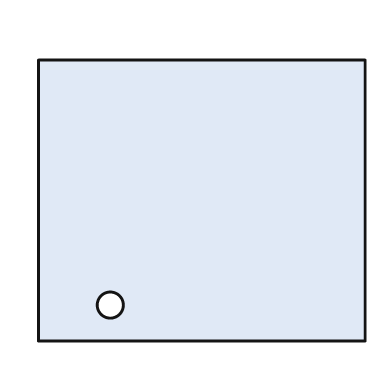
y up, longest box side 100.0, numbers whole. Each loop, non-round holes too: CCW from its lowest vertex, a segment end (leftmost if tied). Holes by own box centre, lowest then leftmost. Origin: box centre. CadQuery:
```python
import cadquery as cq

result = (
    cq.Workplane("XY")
    .moveTo(-50.0, -43.0)
    .lineTo(50.0, -43.0)
    .lineTo(50.0, 43.0)
    .lineTo(-50.0, 43.0)
    .close()
    .moveTo(-28.0, -32.0)
    .circle(4.0)
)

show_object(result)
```